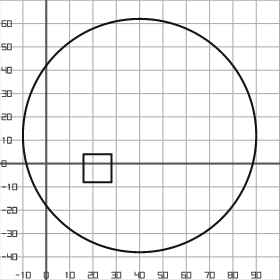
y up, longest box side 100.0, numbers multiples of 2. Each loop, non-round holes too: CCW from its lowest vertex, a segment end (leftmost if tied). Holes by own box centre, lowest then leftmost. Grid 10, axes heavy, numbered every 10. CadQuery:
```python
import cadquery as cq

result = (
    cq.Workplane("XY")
    .moveTo(40.0, 12.0)
    .circle(50.0)
    .moveTo(16.0, -8.0)
    .lineTo(28.0, -8.0)
    .lineTo(28.0, 4.0)
    .lineTo(16.0, 4.0)
    .close()
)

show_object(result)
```